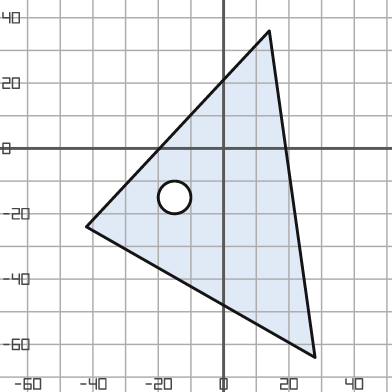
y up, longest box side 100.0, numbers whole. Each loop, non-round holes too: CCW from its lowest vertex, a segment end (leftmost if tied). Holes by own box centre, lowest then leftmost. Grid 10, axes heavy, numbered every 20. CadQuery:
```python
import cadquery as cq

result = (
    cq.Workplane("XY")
    .moveTo(28.0, -64.0)
    .lineTo(14.0, 36.0)
    .lineTo(-42.0, -24.0)
    .close()
    .moveTo(-15.0, -15.0)
    .circle(5.0)
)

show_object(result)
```